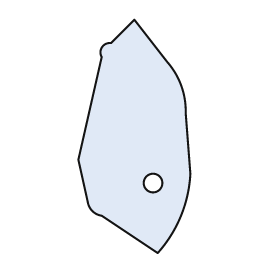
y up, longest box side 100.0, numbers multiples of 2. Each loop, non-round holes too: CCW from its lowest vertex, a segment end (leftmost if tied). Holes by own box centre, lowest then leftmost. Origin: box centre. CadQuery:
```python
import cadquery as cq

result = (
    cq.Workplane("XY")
    .moveTo(10.0, -50.0)
    .threePointArc((20.0, -34.0), (24.0, -16.0))
    .lineTo(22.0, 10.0)
    .threePointArc((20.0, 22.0), (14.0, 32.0))
    .lineTo(0.0, 50.0)
    .lineTo(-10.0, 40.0)
    .threePointArc((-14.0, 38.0), (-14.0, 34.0))
    .lineTo(-24.0, -10.0)
    .lineTo(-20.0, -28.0)
    .threePointArc((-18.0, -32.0), (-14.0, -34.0))
    .close()
    .moveTo(8.0, -20.0)
    .circle(4.0)
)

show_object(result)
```